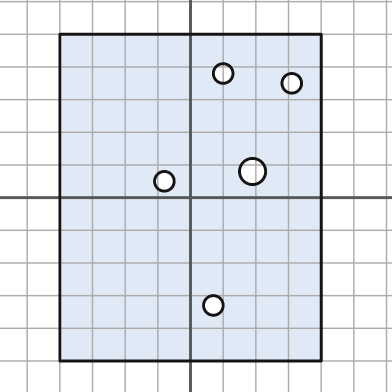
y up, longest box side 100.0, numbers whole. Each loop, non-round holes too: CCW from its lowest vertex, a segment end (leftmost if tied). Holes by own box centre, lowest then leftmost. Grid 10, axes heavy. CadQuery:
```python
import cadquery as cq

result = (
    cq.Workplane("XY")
    .moveTo(-40.0, -50.0)
    .lineTo(40.0, -50.0)
    .lineTo(40.0, 50.0)
    .lineTo(-40.0, 50.0)
    .close()
    .moveTo(7.0, -33.0)
    .circle(3.0)
    .moveTo(-8.0, 5.0)
    .circle(3.0)
    .moveTo(19.0, 8.0)
    .circle(4.0)
    .moveTo(31.0, 35.0)
    .circle(3.0)
    .moveTo(10.0, 38.0)
    .circle(3.0)
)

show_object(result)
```